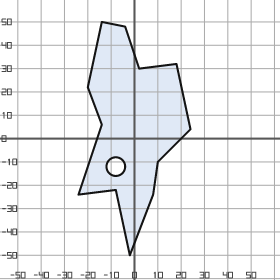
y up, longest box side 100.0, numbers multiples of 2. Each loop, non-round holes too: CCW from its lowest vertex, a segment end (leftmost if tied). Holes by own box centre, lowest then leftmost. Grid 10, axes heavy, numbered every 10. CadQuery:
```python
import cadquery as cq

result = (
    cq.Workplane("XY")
    .moveTo(-2.0, -50.0)
    .lineTo(8.0, -24.0)
    .lineTo(10.0, -10.0)
    .lineTo(24.0, 4.0)
    .lineTo(18.0, 32.0)
    .lineTo(2.0, 30.0)
    .lineTo(-4.0, 48.0)
    .lineTo(-14.0, 50.0)
    .lineTo(-20.0, 22.0)
    .lineTo(-14.0, 6.0)
    .lineTo(-24.0, -24.0)
    .lineTo(-8.0, -22.0)
    .close()
    .moveTo(-8.0, -12.0)
    .circle(4.0)
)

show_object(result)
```